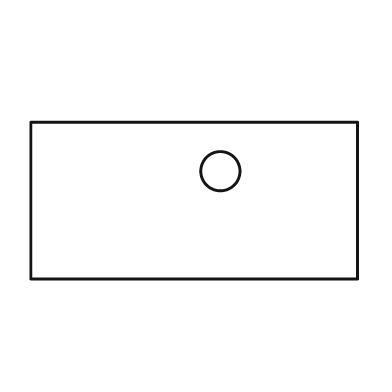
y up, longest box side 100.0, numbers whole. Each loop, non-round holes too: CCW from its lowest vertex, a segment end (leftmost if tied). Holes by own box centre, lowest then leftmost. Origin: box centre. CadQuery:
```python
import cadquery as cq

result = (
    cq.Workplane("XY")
    .moveTo(-50.0, -24.0)
    .lineTo(50.0, -24.0)
    .lineTo(50.0, 24.0)
    .lineTo(-50.0, 24.0)
    .close()
    .moveTo(8.0, 9.0)
    .circle(6.0)
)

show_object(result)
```